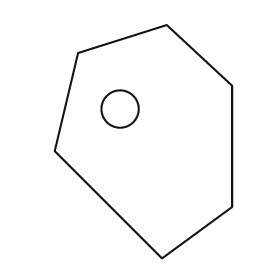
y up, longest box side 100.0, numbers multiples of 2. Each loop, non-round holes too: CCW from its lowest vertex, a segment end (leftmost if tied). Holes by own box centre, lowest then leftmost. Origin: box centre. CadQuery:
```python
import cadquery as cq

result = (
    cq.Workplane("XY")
    .moveTo(8.0, -50.0)
    .lineTo(38.0, -28.0)
    .lineTo(38.0, 24.0)
    .lineTo(10.0, 50.0)
    .lineTo(-28.0, 38.0)
    .lineTo(-38.0, -4.0)
    .close()
    .moveTo(-10.0, 14.0)
    .circle(8.0)
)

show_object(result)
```